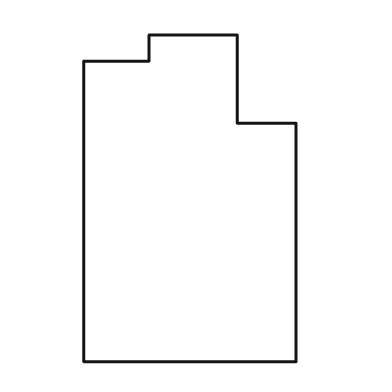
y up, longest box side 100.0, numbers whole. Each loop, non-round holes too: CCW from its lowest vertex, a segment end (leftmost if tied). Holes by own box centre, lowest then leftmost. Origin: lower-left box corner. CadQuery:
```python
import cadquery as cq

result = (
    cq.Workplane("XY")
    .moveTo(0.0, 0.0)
    .lineTo(65.0, 0.0)
    .lineTo(65.0, 73.0)
    .lineTo(47.0, 73.0)
    .lineTo(47.0, 100.0)
    .lineTo(20.0, 100.0)
    .lineTo(20.0, 92.0)
    .lineTo(0.0, 92.0)
    .close()
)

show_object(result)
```